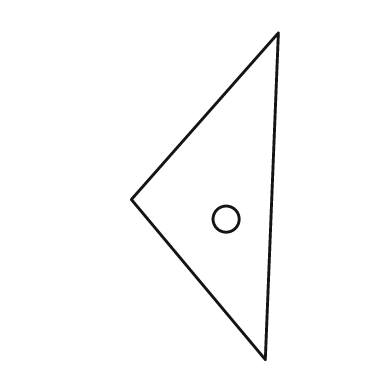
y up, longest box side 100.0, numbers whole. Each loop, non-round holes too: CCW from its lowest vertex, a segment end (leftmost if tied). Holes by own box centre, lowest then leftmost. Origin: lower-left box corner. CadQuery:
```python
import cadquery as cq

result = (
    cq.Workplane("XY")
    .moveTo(41.0, 0.0)
    .lineTo(45.0, 100.0)
    .lineTo(0.0, 49.0)
    .close()
    .moveTo(29.0, 43.0)
    .circle(4.0)
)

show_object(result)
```